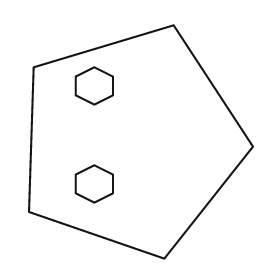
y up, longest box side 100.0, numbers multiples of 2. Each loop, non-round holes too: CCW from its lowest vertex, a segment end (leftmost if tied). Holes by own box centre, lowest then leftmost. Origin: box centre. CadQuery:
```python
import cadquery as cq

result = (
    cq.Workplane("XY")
    .moveTo(10.0, -50.0)
    .lineTo(48.0, -2.0)
    .lineTo(14.0, 50.0)
    .lineTo(-46.0, 32.0)
    .lineTo(-48.0, -30.0)
    .close()
    .moveTo(-20.0, -26.0)
    .lineTo(-12.0, -22.0)
    .lineTo(-12.0, -14.0)
    .lineTo(-20.0, -10.0)
    .lineTo(-28.0, -14.0)
    .lineTo(-28.0, -22.0)
    .close()
    .moveTo(-20.0, 16.0)
    .lineTo(-12.0, 20.0)
    .lineTo(-12.0, 28.0)
    .lineTo(-20.0, 32.0)
    .lineTo(-28.0, 28.0)
    .lineTo(-28.0, 20.0)
    .close()
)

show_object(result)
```